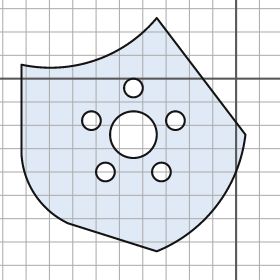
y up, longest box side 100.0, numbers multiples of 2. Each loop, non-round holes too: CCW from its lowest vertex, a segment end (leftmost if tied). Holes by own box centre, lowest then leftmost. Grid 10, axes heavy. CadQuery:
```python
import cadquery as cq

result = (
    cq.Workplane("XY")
    .moveTo(-34.0, -74.0)
    .threePointArc((-8.0, -54.0), (4.0, -24.0))
    .lineTo(-34.0, 26.0)
    .threePointArc((-60.0, 8.0), (-92.0, 6.0))
    .lineTo(-92.0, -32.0)
    .threePointArc((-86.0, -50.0), (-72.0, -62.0))
    .close()
    .moveTo(-56.0, -40.0)
    .circle(4.0)
    .moveTo(-32.0, -40.0)
    .circle(4.0)
    .moveTo(-44.0, -24.0)
    .circle(10.0)
    .moveTo(-62.0, -18.0)
    .circle(4.0)
    .moveTo(-26.0, -18.0)
    .circle(4.0)
    .moveTo(-44.0, -4.0)
    .circle(4.0)
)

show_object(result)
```